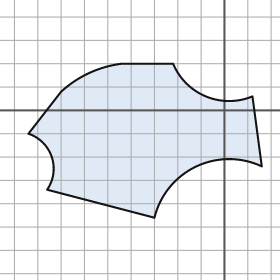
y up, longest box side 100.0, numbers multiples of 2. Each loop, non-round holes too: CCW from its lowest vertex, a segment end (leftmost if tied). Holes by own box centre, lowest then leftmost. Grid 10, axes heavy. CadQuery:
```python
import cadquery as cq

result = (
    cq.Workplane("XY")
    .moveTo(-30.0, -46.0)
    .threePointArc((-12.0, -24.0), (16.0, -24.0))
    .lineTo(12.0, 6.0)
    .threePointArc((-8.0, 6.0), (-22.0, 20.0))
    .lineTo(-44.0, 20.0)
    .threePointArc((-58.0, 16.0), (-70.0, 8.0))
    .lineTo(-84.0, -10.0)
    .threePointArc((-74.0, -20.0), (-76.0, -34.0))
    .close()
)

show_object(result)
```